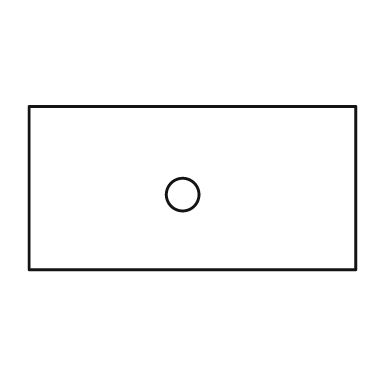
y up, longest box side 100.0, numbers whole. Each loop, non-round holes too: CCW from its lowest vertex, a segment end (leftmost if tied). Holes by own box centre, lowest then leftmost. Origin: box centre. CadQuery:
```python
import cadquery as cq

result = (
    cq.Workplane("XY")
    .moveTo(-50.0, -25.0)
    .lineTo(50.0, -25.0)
    .lineTo(50.0, 25.0)
    .lineTo(-50.0, 25.0)
    .close()
    .moveTo(-3.0, -2.0)
    .circle(5.0)
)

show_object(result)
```